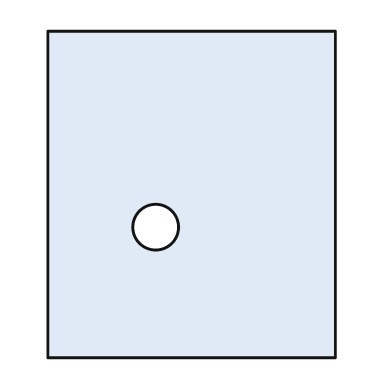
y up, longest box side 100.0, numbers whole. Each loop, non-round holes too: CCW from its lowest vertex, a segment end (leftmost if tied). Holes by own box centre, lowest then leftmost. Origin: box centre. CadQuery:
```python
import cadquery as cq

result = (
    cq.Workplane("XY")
    .moveTo(-44.0, -50.0)
    .lineTo(44.0, -50.0)
    .lineTo(44.0, 50.0)
    .lineTo(-44.0, 50.0)
    .close()
    .moveTo(-11.0, -10.0)
    .circle(7.0)
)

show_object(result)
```